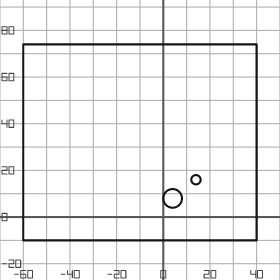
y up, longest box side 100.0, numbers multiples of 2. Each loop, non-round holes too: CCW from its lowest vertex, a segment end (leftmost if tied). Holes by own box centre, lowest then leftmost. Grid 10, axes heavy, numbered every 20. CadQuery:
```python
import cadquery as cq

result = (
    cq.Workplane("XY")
    .moveTo(-60.0, -10.0)
    .lineTo(40.0, -10.0)
    .lineTo(40.0, 74.0)
    .lineTo(-60.0, 74.0)
    .close()
    .moveTo(4.0, 8.0)
    .circle(4.0)
    .moveTo(14.0, 16.0)
    .circle(2.0)
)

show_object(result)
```